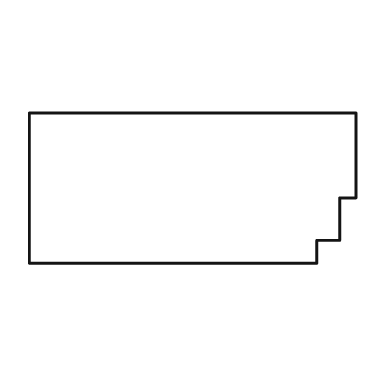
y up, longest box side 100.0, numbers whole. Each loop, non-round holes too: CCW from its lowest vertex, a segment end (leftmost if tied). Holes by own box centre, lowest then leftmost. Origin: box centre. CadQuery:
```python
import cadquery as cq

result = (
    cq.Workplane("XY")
    .moveTo(-50.0, -23.0)
    .lineTo(38.0, -23.0)
    .lineTo(38.0, -16.0)
    .lineTo(45.0, -16.0)
    .lineTo(45.0, -3.0)
    .lineTo(50.0, -3.0)
    .lineTo(50.0, 23.0)
    .lineTo(-50.0, 23.0)
    .close()
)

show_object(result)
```